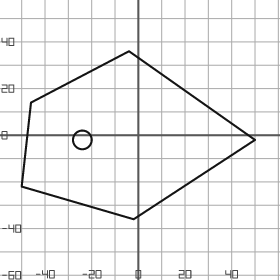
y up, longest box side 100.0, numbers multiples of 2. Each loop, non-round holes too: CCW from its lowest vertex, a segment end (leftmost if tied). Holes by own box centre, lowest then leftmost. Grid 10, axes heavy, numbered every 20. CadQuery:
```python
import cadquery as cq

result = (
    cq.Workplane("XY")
    .moveTo(-2.0, -36.0)
    .lineTo(50.0, -2.0)
    .lineTo(-4.0, 36.0)
    .lineTo(-46.0, 14.0)
    .lineTo(-50.0, -22.0)
    .close()
    .moveTo(-24.0, -2.0)
    .circle(4.0)
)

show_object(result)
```